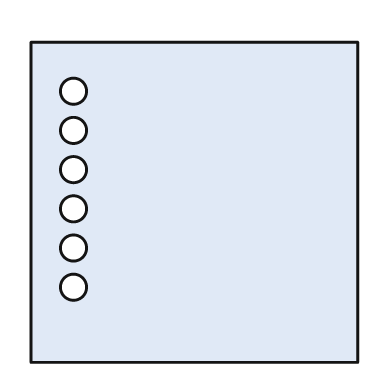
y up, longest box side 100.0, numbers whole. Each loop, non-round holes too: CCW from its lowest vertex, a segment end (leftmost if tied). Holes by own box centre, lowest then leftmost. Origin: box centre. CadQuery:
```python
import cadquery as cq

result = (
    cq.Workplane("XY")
    .moveTo(-50.0, -49.0)
    .lineTo(50.0, -49.0)
    .lineTo(50.0, 49.0)
    .lineTo(-50.0, 49.0)
    .close()
    .moveTo(-37.0, -26.0)
    .circle(4.0)
    .moveTo(-37.0, -14.0)
    .circle(4.0)
    .moveTo(-37.0, -2.0)
    .circle(4.0)
    .moveTo(-37.0, 10.0)
    .circle(4.0)
    .moveTo(-37.0, 22.0)
    .circle(4.0)
    .moveTo(-37.0, 34.0)
    .circle(4.0)
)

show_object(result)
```